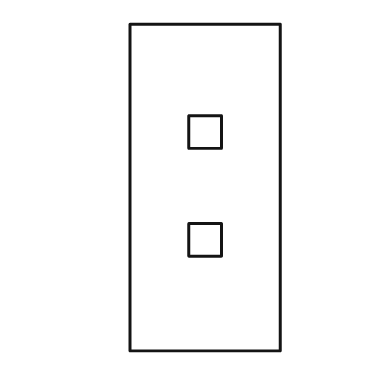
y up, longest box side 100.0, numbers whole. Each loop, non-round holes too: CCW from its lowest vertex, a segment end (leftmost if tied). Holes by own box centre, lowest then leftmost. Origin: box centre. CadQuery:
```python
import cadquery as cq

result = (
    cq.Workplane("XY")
    .moveTo(-23.0, -50.0)
    .lineTo(23.0, -50.0)
    .lineTo(23.0, 50.0)
    .lineTo(-23.0, 50.0)
    .close()
    .moveTo(-5.0, -21.0)
    .lineTo(5.0, -21.0)
    .lineTo(5.0, -11.0)
    .lineTo(-5.0, -11.0)
    .close()
    .moveTo(-5.0, 12.0)
    .lineTo(5.0, 12.0)
    .lineTo(5.0, 22.0)
    .lineTo(-5.0, 22.0)
    .close()
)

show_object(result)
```